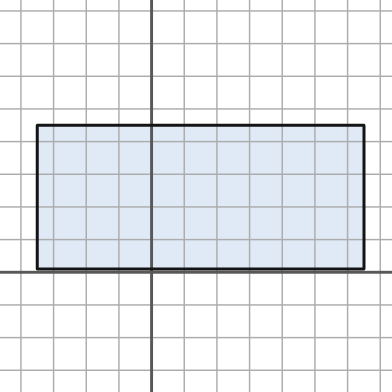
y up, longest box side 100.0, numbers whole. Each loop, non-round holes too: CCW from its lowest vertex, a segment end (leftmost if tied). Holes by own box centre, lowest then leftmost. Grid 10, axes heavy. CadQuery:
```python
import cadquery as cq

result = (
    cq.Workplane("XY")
    .moveTo(-35.0, 1.0)
    .lineTo(65.0, 1.0)
    .lineTo(65.0, 45.0)
    .lineTo(-35.0, 45.0)
    .close()
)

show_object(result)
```